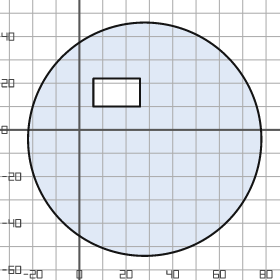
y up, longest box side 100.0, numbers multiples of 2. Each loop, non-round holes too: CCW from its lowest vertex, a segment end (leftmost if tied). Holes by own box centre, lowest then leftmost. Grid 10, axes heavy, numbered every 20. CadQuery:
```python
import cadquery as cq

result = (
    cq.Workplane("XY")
    .moveTo(28.0, -4.0)
    .circle(50.0)
    .moveTo(6.0, 10.0)
    .lineTo(26.0, 10.0)
    .lineTo(26.0, 22.0)
    .lineTo(6.0, 22.0)
    .close()
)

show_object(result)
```